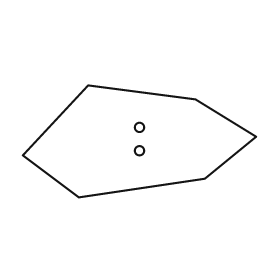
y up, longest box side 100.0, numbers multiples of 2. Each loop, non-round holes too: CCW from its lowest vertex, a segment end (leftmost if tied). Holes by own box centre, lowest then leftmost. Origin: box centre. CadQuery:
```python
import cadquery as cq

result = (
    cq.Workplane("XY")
    .moveTo(-26.0, -24.0)
    .lineTo(28.0, -16.0)
    .lineTo(50.0, 2.0)
    .lineTo(24.0, 18.0)
    .lineTo(-22.0, 24.0)
    .lineTo(-50.0, -6.0)
    .close()
    .moveTo(0.0, -4.0)
    .circle(2.0)
    .moveTo(0.0, 6.0)
    .circle(2.0)
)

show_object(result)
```